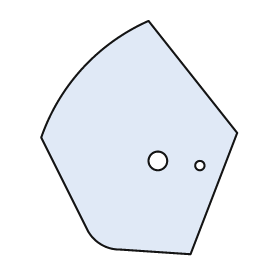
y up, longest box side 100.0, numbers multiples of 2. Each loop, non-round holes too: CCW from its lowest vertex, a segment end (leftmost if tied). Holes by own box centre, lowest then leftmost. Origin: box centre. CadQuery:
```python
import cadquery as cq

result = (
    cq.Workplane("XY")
    .moveTo(22.0, -50.0)
    .lineTo(42.0, 2.0)
    .lineTo(4.0, 50.0)
    .threePointArc((-24.0, 30.0), (-42.0, 0.0))
    .lineTo(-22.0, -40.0)
    .threePointArc((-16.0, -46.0), (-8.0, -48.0))
    .close()
    .moveTo(26.0, -12.0)
    .circle(2.0)
    .moveTo(8.0, -10.0)
    .circle(4.0)
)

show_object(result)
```